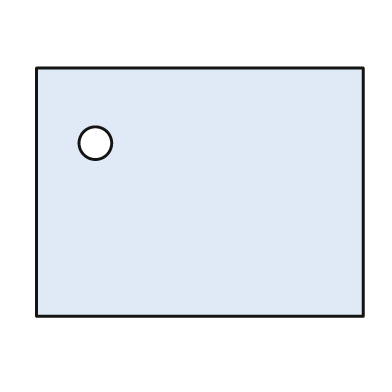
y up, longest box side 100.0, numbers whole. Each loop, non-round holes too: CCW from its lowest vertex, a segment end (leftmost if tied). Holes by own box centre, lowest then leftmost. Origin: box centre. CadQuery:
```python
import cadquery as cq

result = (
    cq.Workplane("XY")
    .moveTo(-50.0, -38.0)
    .lineTo(50.0, -38.0)
    .lineTo(50.0, 38.0)
    .lineTo(-50.0, 38.0)
    .close()
    .moveTo(-32.0, 15.0)
    .circle(5.0)
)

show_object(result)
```